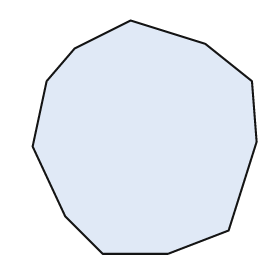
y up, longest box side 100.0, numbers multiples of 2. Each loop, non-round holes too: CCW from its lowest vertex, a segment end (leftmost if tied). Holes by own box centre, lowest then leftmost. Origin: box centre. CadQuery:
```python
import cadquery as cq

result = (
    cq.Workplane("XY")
    .moveTo(-18.0, -50.0)
    .lineTo(10.0, -50.0)
    .lineTo(36.0, -40.0)
    .lineTo(48.0, -2.0)
    .lineTo(46.0, 24.0)
    .lineTo(26.0, 40.0)
    .lineTo(-6.0, 50.0)
    .lineTo(-30.0, 38.0)
    .lineTo(-42.0, 24.0)
    .lineTo(-48.0, -4.0)
    .lineTo(-34.0, -34.0)
    .close()
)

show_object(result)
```